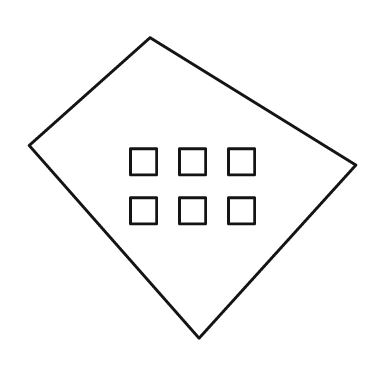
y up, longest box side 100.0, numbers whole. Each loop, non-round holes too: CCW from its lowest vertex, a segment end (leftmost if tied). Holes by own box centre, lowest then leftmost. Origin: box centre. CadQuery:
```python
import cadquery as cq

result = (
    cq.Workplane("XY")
    .moveTo(2.0, -46.0)
    .lineTo(50.0, 7.0)
    .lineTo(-13.0, 46.0)
    .lineTo(-50.0, 13.0)
    .close()
    .moveTo(-19.0, -11.0)
    .lineTo(-11.0, -11.0)
    .lineTo(-11.0, -3.0)
    .lineTo(-19.0, -3.0)
    .close()
    .moveTo(-4.0, -11.0)
    .lineTo(4.0, -11.0)
    .lineTo(4.0, -3.0)
    .lineTo(-4.0, -3.0)
    .close()
    .moveTo(11.0, -11.0)
    .lineTo(19.0, -11.0)
    .lineTo(19.0, -3.0)
    .lineTo(11.0, -3.0)
    .close()
    .moveTo(-19.0, 4.0)
    .lineTo(-11.0, 4.0)
    .lineTo(-11.0, 12.0)
    .lineTo(-19.0, 12.0)
    .close()
    .moveTo(-4.0, 4.0)
    .lineTo(4.0, 4.0)
    .lineTo(4.0, 12.0)
    .lineTo(-4.0, 12.0)
    .close()
    .moveTo(11.0, 4.0)
    .lineTo(19.0, 4.0)
    .lineTo(19.0, 12.0)
    .lineTo(11.0, 12.0)
    .close()
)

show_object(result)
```